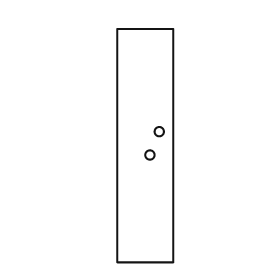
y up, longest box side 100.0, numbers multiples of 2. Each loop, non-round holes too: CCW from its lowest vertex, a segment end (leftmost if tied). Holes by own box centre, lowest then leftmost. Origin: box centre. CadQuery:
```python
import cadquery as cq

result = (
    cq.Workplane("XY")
    .moveTo(-12.0, -50.0)
    .lineTo(12.0, -50.0)
    .lineTo(12.0, 50.0)
    .lineTo(-12.0, 50.0)
    .close()
    .moveTo(2.0, -4.0)
    .circle(2.0)
    .moveTo(6.0, 6.0)
    .circle(2.0)
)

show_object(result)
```